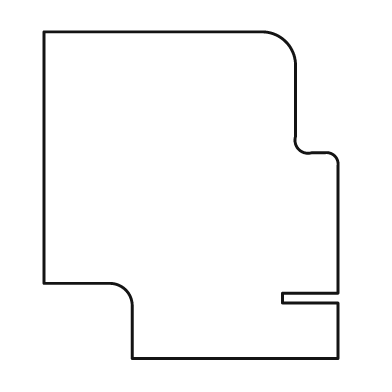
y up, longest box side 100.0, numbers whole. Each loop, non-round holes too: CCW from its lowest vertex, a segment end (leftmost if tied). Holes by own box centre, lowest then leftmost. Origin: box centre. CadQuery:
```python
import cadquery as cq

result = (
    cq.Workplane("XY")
    .moveTo(-18.0, -50.0)
    .lineTo(45.0, -50.0)
    .lineTo(45.0, -33.0)
    .lineTo(28.0, -33.0)
    .lineTo(28.0, -30.0)
    .lineTo(45.0, -30.0)
    .lineTo(45.0, 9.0)
    .threePointArc((44.0, 12.0), (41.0, 13.0))
    .lineTo(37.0, 13.0)
    .threePointArc((33.0, 14.0), (32.0, 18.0))
    .lineTo(32.0, 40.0)
    .threePointArc((29.0, 47.0), (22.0, 50.0))
    .lineTo(-45.0, 50.0)
    .lineTo(-45.0, -27.0)
    .lineTo(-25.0, -27.0)
    .threePointArc((-20.0, -29.0), (-18.0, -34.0))
    .close()
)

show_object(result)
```